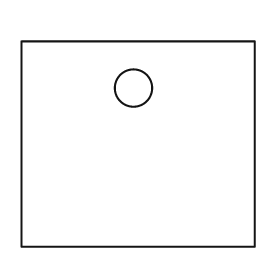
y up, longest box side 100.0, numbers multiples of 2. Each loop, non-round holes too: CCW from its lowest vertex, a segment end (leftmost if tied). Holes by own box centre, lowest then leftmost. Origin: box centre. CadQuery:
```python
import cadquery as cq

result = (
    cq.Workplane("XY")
    .moveTo(-50.0, -44.0)
    .lineTo(50.0, -44.0)
    .lineTo(50.0, 44.0)
    .lineTo(-50.0, 44.0)
    .close()
    .moveTo(-2.0, 24.0)
    .circle(8.0)
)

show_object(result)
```